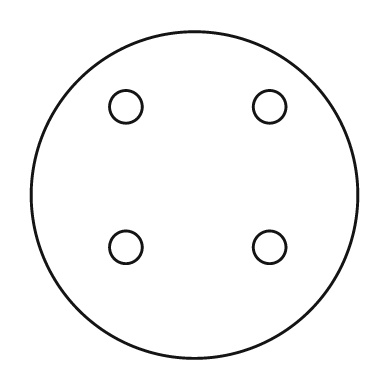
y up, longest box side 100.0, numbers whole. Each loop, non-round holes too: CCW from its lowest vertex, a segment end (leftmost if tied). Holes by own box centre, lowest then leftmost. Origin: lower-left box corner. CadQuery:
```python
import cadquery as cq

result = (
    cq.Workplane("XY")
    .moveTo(50.0, 50.0)
    .circle(50.0)
    .moveTo(29.0, 34.0)
    .circle(5.0)
    .moveTo(73.0, 34.0)
    .circle(5.0)
    .moveTo(29.0, 77.0)
    .circle(5.0)
    .moveTo(73.0, 77.0)
    .circle(5.0)
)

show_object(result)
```